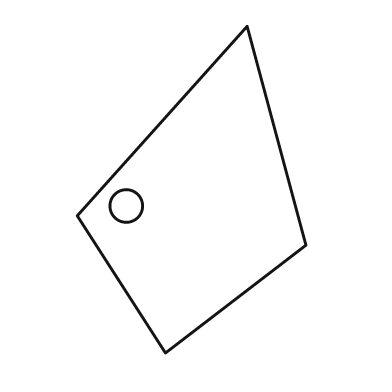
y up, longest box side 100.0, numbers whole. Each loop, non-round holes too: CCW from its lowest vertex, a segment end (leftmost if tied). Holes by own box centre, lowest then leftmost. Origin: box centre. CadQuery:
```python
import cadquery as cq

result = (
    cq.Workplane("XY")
    .moveTo(-8.0, -50.0)
    .lineTo(35.0, -17.0)
    .lineTo(17.0, 50.0)
    .lineTo(-35.0, -8.0)
    .close()
    .moveTo(-20.0, -5.0)
    .circle(5.0)
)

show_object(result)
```